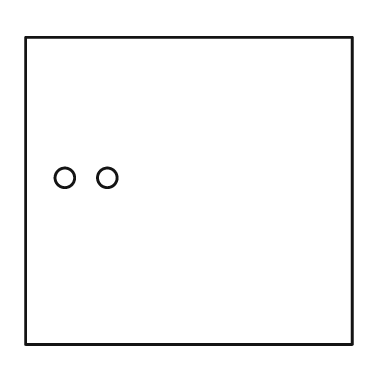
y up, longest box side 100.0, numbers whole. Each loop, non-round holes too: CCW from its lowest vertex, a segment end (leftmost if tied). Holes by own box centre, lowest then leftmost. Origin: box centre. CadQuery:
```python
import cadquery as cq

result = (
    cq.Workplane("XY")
    .moveTo(-50.0, -47.0)
    .lineTo(50.0, -47.0)
    .lineTo(50.0, 47.0)
    .lineTo(-50.0, 47.0)
    .close()
    .moveTo(-38.0, 4.0)
    .circle(3.0)
    .moveTo(-25.0, 4.0)
    .circle(3.0)
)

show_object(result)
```